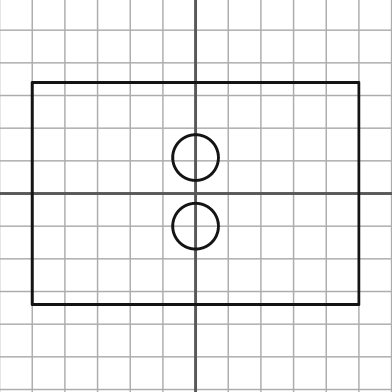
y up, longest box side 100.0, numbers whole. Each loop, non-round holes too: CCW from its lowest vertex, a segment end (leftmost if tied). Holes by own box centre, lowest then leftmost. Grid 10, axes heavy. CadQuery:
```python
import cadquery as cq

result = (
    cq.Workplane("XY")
    .moveTo(-50.0, -34.0)
    .lineTo(50.0, -34.0)
    .lineTo(50.0, 34.0)
    .lineTo(-50.0, 34.0)
    .close()
    .moveTo(0.0, -10.0)
    .circle(7.0)
    .moveTo(0.0, 11.0)
    .circle(7.0)
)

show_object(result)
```